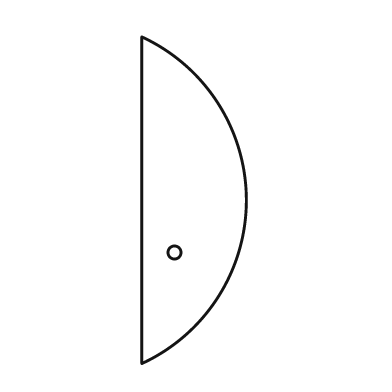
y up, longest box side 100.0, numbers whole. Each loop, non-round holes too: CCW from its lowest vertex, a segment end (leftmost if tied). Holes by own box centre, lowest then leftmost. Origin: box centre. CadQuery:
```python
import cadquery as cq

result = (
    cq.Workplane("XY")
    .moveTo(-16.0, -50.0)
    .threePointArc((16.0, 0.0), (-16.0, 50.0))
    .close()
    .moveTo(-6.0, -16.0)
    .circle(2.0)
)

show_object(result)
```